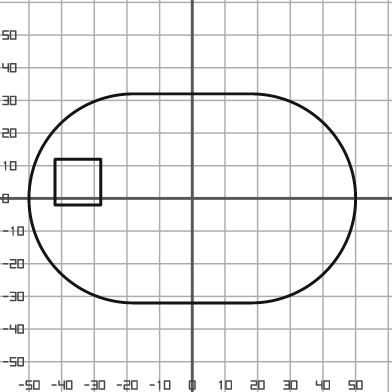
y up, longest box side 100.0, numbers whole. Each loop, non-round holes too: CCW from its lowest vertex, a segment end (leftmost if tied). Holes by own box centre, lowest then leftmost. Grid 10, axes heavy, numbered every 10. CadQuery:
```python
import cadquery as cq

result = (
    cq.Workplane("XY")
    .moveTo(-18.0, -32.0)
    .lineTo(18.0, -32.0)
    .threePointArc((50.0, 0.0), (18.0, 32.0))
    .lineTo(-18.0, 32.0)
    .threePointArc((-50.0, 0.0), (-18.0, -32.0))
    .close()
    .moveTo(-42.0, -2.0)
    .lineTo(-28.0, -2.0)
    .lineTo(-28.0, 12.0)
    .lineTo(-42.0, 12.0)
    .close()
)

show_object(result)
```